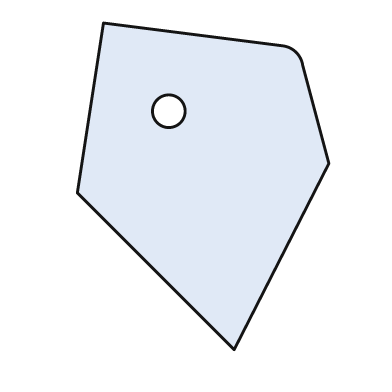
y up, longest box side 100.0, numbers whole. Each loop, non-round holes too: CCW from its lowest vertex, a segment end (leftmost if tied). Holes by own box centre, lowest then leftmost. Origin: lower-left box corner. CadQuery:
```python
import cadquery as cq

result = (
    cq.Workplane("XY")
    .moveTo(48.0, 0.0)
    .lineTo(77.0, 57.0)
    .lineTo(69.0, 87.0)
    .threePointArc((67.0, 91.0), (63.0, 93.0))
    .lineTo(8.0, 100.0)
    .lineTo(0.0, 48.0)
    .close()
    .moveTo(28.0, 73.0)
    .circle(5.0)
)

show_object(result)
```